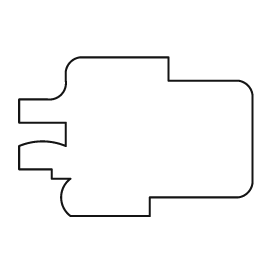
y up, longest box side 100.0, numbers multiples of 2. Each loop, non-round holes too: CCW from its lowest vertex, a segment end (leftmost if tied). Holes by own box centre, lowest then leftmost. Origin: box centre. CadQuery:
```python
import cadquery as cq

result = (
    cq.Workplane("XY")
    .moveTo(-28.0, -34.0)
    .lineTo(6.0, -34.0)
    .lineTo(6.0, -26.0)
    .lineTo(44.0, -26.0)
    .threePointArc((48.0, -24.0), (50.0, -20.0))
    .lineTo(50.0, 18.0)
    .threePointArc((48.0, 22.0), (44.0, 24.0))
    .lineTo(14.0, 24.0)
    .lineTo(14.0, 34.0)
    .lineTo(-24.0, 34.0)
    .threePointArc((-28.0, 32.0), (-30.0, 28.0))
    .lineTo(-30.0, 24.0)
    .threePointArc((-32.0, 18.0), (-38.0, 16.0))
    .lineTo(-50.0, 16.0)
    .lineTo(-50.0, 6.0)
    .lineTo(-30.0, 6.0)
    .lineTo(-30.0, -4.0)
    .threePointArc((-40.0, -2.0), (-50.0, -4.0))
    .lineTo(-50.0, -14.0)
    .lineTo(-36.0, -14.0)
    .lineTo(-36.0, -18.0)
    .lineTo(-28.0, -18.0)
    .threePointArc((-32.0, -26.0), (-28.0, -34.0))
    .close()
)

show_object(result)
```